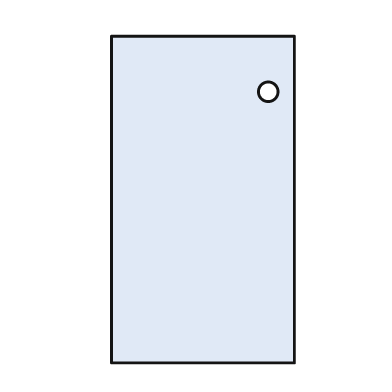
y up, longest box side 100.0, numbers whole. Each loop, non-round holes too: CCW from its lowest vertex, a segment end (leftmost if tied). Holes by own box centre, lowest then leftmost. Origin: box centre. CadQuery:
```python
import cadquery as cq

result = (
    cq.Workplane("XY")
    .moveTo(-28.0, -50.0)
    .lineTo(28.0, -50.0)
    .lineTo(28.0, 50.0)
    .lineTo(-28.0, 50.0)
    .close()
    .moveTo(20.0, 33.0)
    .circle(3.0)
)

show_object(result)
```